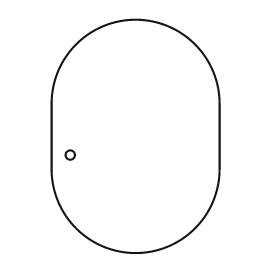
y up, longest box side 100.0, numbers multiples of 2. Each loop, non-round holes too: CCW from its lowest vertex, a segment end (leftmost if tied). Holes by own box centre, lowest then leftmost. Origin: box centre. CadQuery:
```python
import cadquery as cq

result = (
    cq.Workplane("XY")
    .moveTo(-36.0, -14.0)
    .threePointArc((0.0, -50.0), (36.0, -14.0))
    .lineTo(36.0, 14.0)
    .threePointArc((0.0, 50.0), (-36.0, 14.0))
    .close()
    .moveTo(-28.0, -8.0)
    .circle(2.0)
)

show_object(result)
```